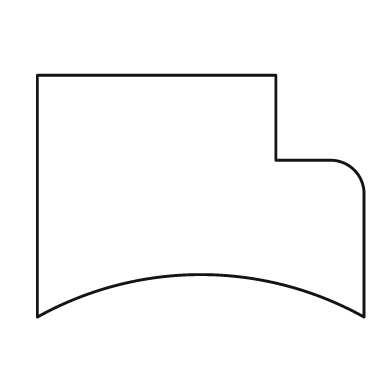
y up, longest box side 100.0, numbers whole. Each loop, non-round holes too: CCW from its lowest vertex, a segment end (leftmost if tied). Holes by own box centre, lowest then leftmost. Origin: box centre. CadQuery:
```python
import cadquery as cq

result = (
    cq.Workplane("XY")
    .moveTo(-50.0, -37.0)
    .threePointArc((0.0, -24.0), (50.0, -37.0))
    .lineTo(50.0, 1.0)
    .threePointArc((47.0, 8.0), (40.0, 11.0))
    .lineTo(23.0, 11.0)
    .lineTo(23.0, 37.0)
    .lineTo(-50.0, 37.0)
    .close()
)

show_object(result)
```